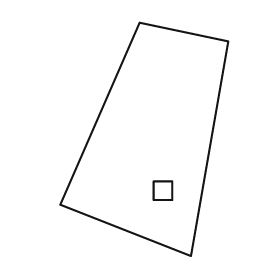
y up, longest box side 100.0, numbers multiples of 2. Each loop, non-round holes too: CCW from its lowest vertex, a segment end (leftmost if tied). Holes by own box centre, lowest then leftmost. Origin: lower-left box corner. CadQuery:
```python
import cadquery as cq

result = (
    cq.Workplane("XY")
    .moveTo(56.0, 0.0)
    .lineTo(72.0, 92.0)
    .lineTo(34.0, 100.0)
    .lineTo(0.0, 22.0)
    .close()
    .moveTo(40.0, 24.0)
    .lineTo(48.0, 24.0)
    .lineTo(48.0, 32.0)
    .lineTo(40.0, 32.0)
    .close()
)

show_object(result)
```